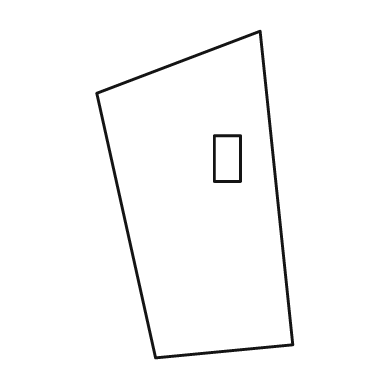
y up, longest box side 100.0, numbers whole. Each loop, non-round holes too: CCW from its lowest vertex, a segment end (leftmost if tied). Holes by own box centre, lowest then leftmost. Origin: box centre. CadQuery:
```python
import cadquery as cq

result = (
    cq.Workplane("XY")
    .moveTo(-12.0, -50.0)
    .lineTo(30.0, -46.0)
    .lineTo(20.0, 50.0)
    .lineTo(-30.0, 31.0)
    .close()
    .moveTo(6.0, 4.0)
    .lineTo(14.0, 4.0)
    .lineTo(14.0, 18.0)
    .lineTo(6.0, 18.0)
    .close()
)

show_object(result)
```